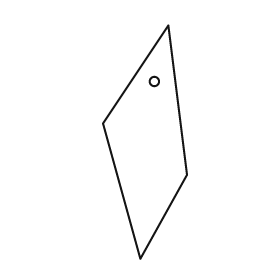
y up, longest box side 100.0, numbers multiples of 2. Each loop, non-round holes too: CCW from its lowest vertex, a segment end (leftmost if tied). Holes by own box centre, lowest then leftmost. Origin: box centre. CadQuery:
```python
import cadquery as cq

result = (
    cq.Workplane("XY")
    .moveTo(-2.0, -50.0)
    .lineTo(18.0, -14.0)
    .lineTo(10.0, 50.0)
    .lineTo(-18.0, 8.0)
    .close()
    .moveTo(4.0, 26.0)
    .circle(2.0)
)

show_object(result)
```